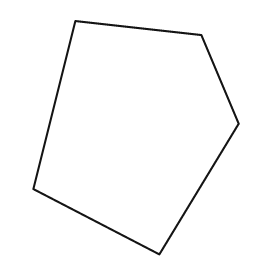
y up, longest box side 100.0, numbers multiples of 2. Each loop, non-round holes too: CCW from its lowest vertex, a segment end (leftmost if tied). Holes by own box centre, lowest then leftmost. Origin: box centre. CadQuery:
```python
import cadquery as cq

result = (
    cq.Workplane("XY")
    .moveTo(10.0, -50.0)
    .lineTo(44.0, 6.0)
    .lineTo(28.0, 44.0)
    .lineTo(-26.0, 50.0)
    .lineTo(-44.0, -22.0)
    .close()
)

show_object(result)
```